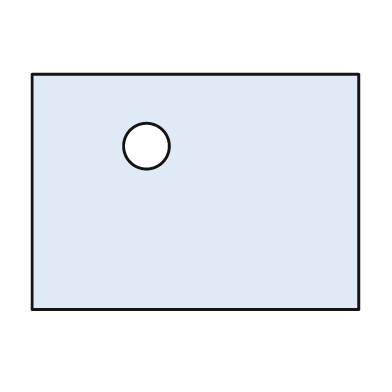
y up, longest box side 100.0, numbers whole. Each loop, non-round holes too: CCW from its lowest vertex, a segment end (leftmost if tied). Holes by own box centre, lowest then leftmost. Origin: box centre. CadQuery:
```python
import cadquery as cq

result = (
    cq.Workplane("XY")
    .moveTo(-50.0, -36.0)
    .lineTo(50.0, -36.0)
    .lineTo(50.0, 36.0)
    .lineTo(-50.0, 36.0)
    .close()
    .moveTo(-15.0, 14.0)
    .circle(7.0)
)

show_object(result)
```